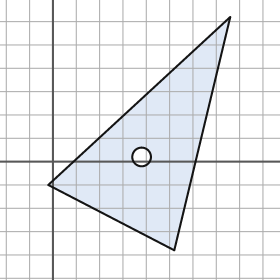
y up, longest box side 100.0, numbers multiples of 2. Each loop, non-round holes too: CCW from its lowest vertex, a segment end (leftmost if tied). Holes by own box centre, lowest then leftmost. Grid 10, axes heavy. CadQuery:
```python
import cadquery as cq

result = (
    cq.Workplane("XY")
    .moveTo(52.0, -38.0)
    .lineTo(76.0, 62.0)
    .lineTo(-2.0, -10.0)
    .close()
    .moveTo(38.0, 2.0)
    .circle(4.0)
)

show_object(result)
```